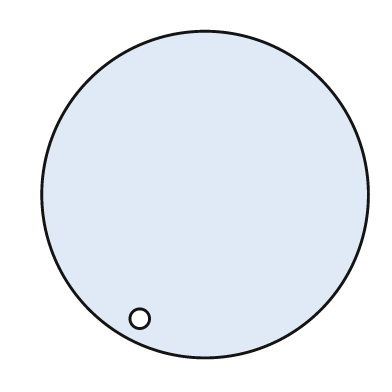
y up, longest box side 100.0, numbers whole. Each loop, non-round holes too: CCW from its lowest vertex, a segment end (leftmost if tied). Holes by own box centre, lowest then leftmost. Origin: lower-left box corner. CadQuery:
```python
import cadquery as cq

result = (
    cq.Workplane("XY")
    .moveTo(50.0, 50.0)
    .circle(50.0)
    .moveTo(30.0, 12.0)
    .circle(3.0)
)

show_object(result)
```